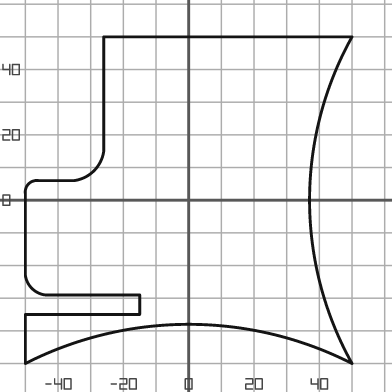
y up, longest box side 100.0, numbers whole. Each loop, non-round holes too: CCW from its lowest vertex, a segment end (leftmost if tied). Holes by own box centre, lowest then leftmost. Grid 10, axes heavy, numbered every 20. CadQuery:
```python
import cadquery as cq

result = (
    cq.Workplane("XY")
    .moveTo(-50.0, -50.0)
    .threePointArc((0.0, -38.0), (50.0, -50.0))
    .threePointArc((37.0, 0.0), (50.0, 50.0))
    .lineTo(-26.0, 50.0)
    .lineTo(-26.0, 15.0)
    .threePointArc((-29.0, 9.0), (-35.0, 6.0))
    .lineTo(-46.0, 6.0)
    .threePointArc((-49.0, 5.0), (-50.0, 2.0))
    .lineTo(-50.0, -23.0)
    .threePointArc((-48.0, -27.0), (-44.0, -29.0))
    .lineTo(-15.0, -29.0)
    .lineTo(-15.0, -35.0)
    .lineTo(-50.0, -35.0)
    .close()
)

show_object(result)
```